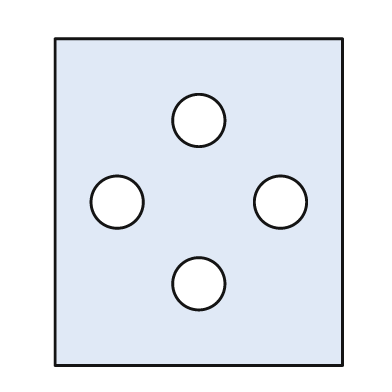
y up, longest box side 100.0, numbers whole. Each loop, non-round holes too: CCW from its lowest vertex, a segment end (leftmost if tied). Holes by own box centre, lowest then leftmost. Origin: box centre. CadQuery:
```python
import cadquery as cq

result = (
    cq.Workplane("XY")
    .moveTo(-44.0, -50.0)
    .lineTo(44.0, -50.0)
    .lineTo(44.0, 50.0)
    .lineTo(-44.0, 50.0)
    .close()
    .moveTo(0.0, -25.0)
    .circle(8.0)
    .moveTo(-25.0, 0.0)
    .circle(8.0)
    .moveTo(25.0, 0.0)
    .circle(8.0)
    .moveTo(0.0, 25.0)
    .circle(8.0)
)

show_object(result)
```